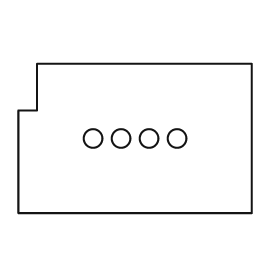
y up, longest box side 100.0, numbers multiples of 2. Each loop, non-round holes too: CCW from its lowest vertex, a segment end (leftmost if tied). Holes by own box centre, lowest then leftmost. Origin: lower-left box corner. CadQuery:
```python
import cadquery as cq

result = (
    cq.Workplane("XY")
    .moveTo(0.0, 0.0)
    .lineTo(100.0, 0.0)
    .lineTo(100.0, 64.0)
    .lineTo(8.0, 64.0)
    .lineTo(8.0, 44.0)
    .lineTo(0.0, 44.0)
    .close()
    .moveTo(32.0, 32.0)
    .circle(4.0)
    .moveTo(44.0, 32.0)
    .circle(4.0)
    .moveTo(56.0, 32.0)
    .circle(4.0)
    .moveTo(68.0, 32.0)
    .circle(4.0)
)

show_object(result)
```